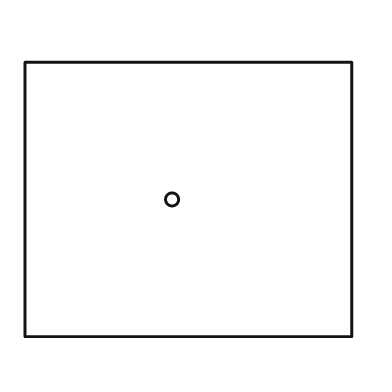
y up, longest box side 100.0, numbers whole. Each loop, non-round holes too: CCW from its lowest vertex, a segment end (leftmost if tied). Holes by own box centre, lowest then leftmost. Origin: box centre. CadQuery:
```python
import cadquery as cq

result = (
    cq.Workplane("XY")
    .moveTo(-50.0, -42.0)
    .lineTo(50.0, -42.0)
    .lineTo(50.0, 42.0)
    .lineTo(-50.0, 42.0)
    .close()
    .moveTo(-5.0, 0.0)
    .circle(2.0)
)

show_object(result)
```